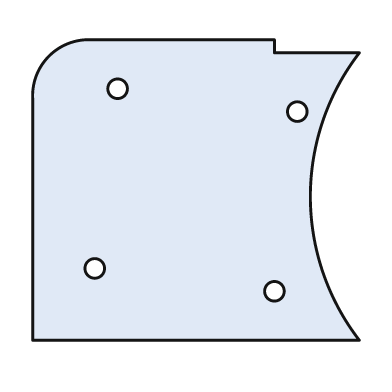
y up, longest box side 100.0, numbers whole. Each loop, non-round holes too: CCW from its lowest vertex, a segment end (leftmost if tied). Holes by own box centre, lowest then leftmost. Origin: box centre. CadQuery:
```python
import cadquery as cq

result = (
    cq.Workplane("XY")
    .moveTo(-50.0, -46.0)
    .lineTo(50.0, -46.0)
    .threePointArc((35.0, -2.0), (50.0, 42.0))
    .lineTo(24.0, 42.0)
    .lineTo(24.0, 46.0)
    .lineTo(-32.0, 46.0)
    .threePointArc((-45.0, 41.0), (-50.0, 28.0))
    .close()
    .moveTo(24.0, -31.0)
    .circle(3.0)
    .moveTo(-31.0, -24.0)
    .circle(3.0)
    .moveTo(31.0, 24.0)
    .circle(3.0)
    .moveTo(-24.0, 31.0)
    .circle(3.0)
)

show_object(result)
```